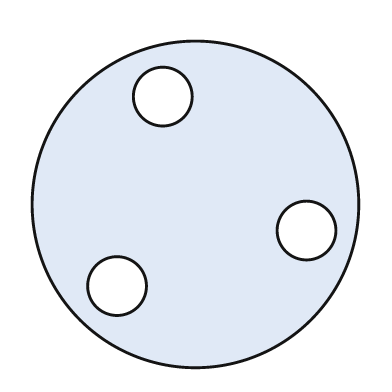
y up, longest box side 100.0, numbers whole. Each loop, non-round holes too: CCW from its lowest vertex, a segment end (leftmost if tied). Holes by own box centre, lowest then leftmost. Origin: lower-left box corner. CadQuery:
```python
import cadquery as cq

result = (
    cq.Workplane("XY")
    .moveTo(50.0, 50.0)
    .circle(50.0)
    .moveTo(26.0, 25.0)
    .circle(9.0)
    .moveTo(84.0, 42.0)
    .circle(9.0)
    .moveTo(40.0, 83.0)
    .circle(9.0)
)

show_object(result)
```